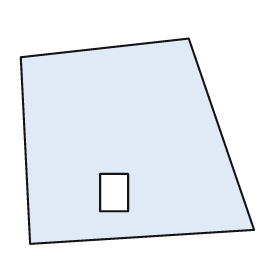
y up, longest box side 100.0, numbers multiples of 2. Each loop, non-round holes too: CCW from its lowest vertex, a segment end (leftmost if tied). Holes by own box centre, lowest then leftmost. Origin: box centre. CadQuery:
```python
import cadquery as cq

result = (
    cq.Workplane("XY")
    .moveTo(-46.0, -44.0)
    .lineTo(50.0, -38.0)
    .lineTo(22.0, 44.0)
    .lineTo(-50.0, 36.0)
    .close()
    .moveTo(-16.0, -30.0)
    .lineTo(-4.0, -30.0)
    .lineTo(-4.0, -14.0)
    .lineTo(-16.0, -14.0)
    .close()
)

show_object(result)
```